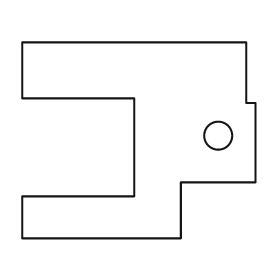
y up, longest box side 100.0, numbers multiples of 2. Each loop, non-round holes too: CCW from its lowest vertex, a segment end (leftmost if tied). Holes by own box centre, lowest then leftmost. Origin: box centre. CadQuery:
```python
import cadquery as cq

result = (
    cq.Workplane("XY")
    .moveTo(-50.0, -42.0)
    .lineTo(18.0, -42.0)
    .lineTo(18.0, -18.0)
    .lineTo(50.0, -18.0)
    .lineTo(50.0, 16.0)
    .lineTo(46.0, 16.0)
    .lineTo(46.0, 42.0)
    .lineTo(-50.0, 42.0)
    .lineTo(-50.0, 18.0)
    .lineTo(-2.0, 18.0)
    .lineTo(-2.0, -24.0)
    .lineTo(-50.0, -24.0)
    .close()
    .moveTo(34.0, 2.0)
    .circle(6.0)
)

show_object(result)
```